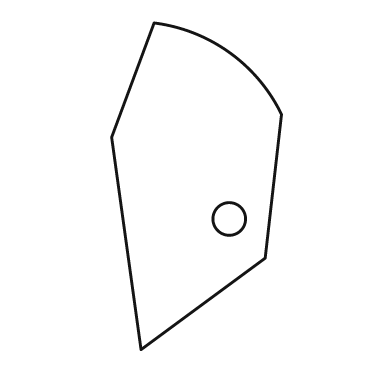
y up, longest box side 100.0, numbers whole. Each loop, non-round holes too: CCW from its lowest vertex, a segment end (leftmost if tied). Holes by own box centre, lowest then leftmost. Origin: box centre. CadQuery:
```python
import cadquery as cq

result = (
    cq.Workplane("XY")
    .moveTo(-17.0, -50.0)
    .lineTo(21.0, -22.0)
    .lineTo(26.0, 22.0)
    .threePointArc((10.0, 41.0), (-13.0, 50.0))
    .lineTo(-26.0, 15.0)
    .close()
    .moveTo(10.0, -10.0)
    .circle(5.0)
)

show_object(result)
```